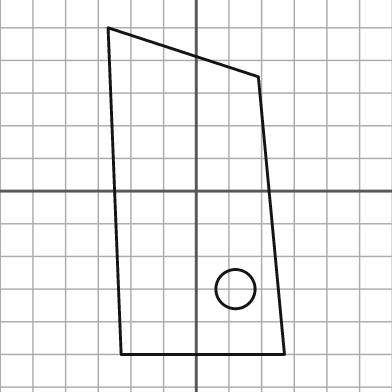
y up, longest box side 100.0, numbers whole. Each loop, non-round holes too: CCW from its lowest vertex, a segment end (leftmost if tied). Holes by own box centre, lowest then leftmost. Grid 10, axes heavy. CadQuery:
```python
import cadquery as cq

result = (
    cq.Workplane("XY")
    .moveTo(-23.0, -50.0)
    .lineTo(27.0, -50.0)
    .lineTo(19.0, 35.0)
    .lineTo(-27.0, 50.0)
    .close()
    .moveTo(12.0, -30.0)
    .circle(6.0)
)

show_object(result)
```